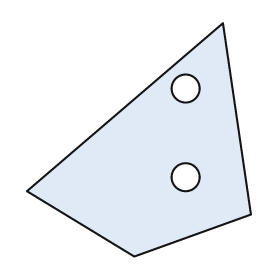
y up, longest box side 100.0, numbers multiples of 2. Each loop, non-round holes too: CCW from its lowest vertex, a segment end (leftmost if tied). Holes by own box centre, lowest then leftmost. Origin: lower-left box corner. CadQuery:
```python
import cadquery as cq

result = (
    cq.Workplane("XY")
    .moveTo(46.0, 0.0)
    .lineTo(96.0, 18.0)
    .lineTo(84.0, 100.0)
    .lineTo(0.0, 28.0)
    .close()
    .moveTo(68.0, 34.0)
    .circle(6.0)
    .moveTo(68.0, 72.0)
    .circle(6.0)
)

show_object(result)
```